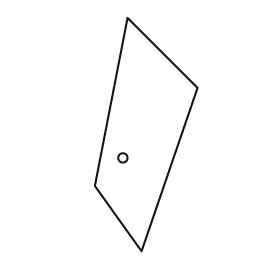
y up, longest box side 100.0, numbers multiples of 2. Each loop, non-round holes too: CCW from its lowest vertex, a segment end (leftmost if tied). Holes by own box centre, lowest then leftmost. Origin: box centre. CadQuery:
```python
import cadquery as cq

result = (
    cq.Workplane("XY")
    .moveTo(-2.0, -50.0)
    .lineTo(22.0, 20.0)
    .lineTo(-8.0, 50.0)
    .lineTo(-22.0, -22.0)
    .close()
    .moveTo(-10.0, -10.0)
    .circle(2.0)
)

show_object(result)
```